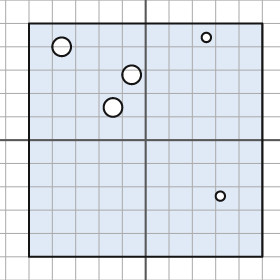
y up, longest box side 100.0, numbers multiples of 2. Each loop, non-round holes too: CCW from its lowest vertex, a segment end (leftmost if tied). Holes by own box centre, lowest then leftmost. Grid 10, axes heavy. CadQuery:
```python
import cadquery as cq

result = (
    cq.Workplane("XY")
    .moveTo(-50.0, -50.0)
    .lineTo(50.0, -50.0)
    .lineTo(50.0, 50.0)
    .lineTo(-50.0, 50.0)
    .close()
    .moveTo(32.0, -24.0)
    .circle(2.0)
    .moveTo(-14.0, 14.0)
    .circle(4.0)
    .moveTo(-6.0, 28.0)
    .circle(4.0)
    .moveTo(-36.0, 40.0)
    .circle(4.0)
    .moveTo(26.0, 44.0)
    .circle(2.0)
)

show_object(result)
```